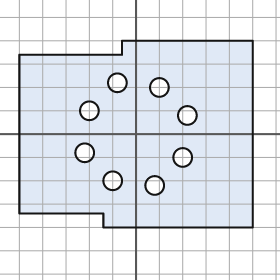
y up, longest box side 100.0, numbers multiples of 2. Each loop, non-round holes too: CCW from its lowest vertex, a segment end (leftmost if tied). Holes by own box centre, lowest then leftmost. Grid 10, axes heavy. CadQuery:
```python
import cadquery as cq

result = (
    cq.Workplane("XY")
    .moveTo(-14.0, -40.0)
    .lineTo(50.0, -40.0)
    .lineTo(50.0, 40.0)
    .lineTo(-6.0, 40.0)
    .lineTo(-6.0, 34.0)
    .lineTo(-50.0, 34.0)
    .lineTo(-50.0, -34.0)
    .lineTo(-14.0, -34.0)
    .close()
    .moveTo(8.0, -22.0)
    .circle(4.0)
    .moveTo(-10.0, -20.0)
    .circle(4.0)
    .moveTo(20.0, -10.0)
    .circle(4.0)
    .moveTo(-22.0, -8.0)
    .circle(4.0)
    .moveTo(22.0, 8.0)
    .circle(4.0)
    .moveTo(-20.0, 10.0)
    .circle(4.0)
    .moveTo(10.0, 20.0)
    .circle(4.0)
    .moveTo(-8.0, 22.0)
    .circle(4.0)
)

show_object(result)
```